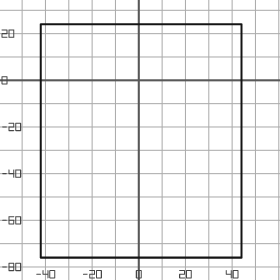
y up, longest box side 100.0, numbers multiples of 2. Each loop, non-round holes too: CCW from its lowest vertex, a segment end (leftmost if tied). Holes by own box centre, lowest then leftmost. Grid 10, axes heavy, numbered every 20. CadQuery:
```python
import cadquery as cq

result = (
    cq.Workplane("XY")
    .moveTo(-42.0, -76.0)
    .lineTo(44.0, -76.0)
    .lineTo(44.0, 24.0)
    .lineTo(-42.0, 24.0)
    .close()
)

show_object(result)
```